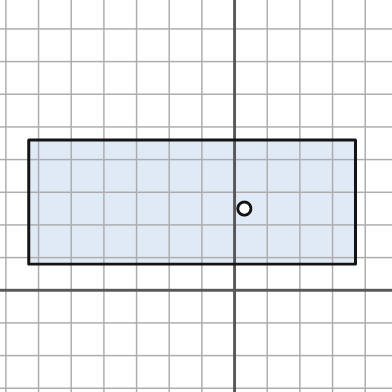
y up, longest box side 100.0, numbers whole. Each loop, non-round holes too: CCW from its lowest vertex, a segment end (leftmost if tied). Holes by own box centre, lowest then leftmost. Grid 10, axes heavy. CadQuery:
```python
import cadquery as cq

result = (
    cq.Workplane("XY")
    .moveTo(-63.0, 8.0)
    .lineTo(37.0, 8.0)
    .lineTo(37.0, 46.0)
    .lineTo(-63.0, 46.0)
    .close()
    .moveTo(3.0, 25.0)
    .circle(2.0)
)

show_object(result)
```